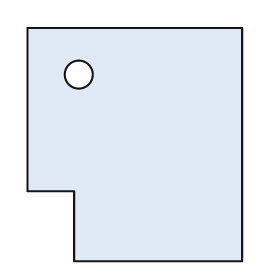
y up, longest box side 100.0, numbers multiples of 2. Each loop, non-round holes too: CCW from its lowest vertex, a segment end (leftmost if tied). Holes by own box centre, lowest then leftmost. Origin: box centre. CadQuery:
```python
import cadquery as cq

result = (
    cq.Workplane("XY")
    .moveTo(-26.0, -50.0)
    .lineTo(46.0, -50.0)
    .lineTo(46.0, 50.0)
    .lineTo(-46.0, 50.0)
    .lineTo(-46.0, -20.0)
    .lineTo(-26.0, -20.0)
    .close()
    .moveTo(-24.0, 30.0)
    .circle(6.0)
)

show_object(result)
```